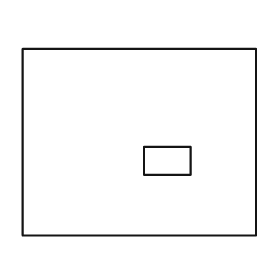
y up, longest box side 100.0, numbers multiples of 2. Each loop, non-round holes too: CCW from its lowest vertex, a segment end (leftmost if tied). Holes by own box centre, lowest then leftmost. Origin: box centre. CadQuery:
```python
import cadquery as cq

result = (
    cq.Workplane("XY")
    .moveTo(-50.0, -40.0)
    .lineTo(50.0, -40.0)
    .lineTo(50.0, 40.0)
    .lineTo(-50.0, 40.0)
    .close()
    .moveTo(2.0, -14.0)
    .lineTo(22.0, -14.0)
    .lineTo(22.0, -2.0)
    .lineTo(2.0, -2.0)
    .close()
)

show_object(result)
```